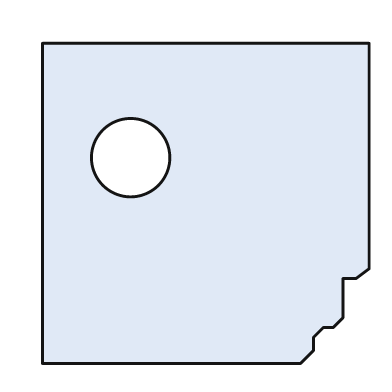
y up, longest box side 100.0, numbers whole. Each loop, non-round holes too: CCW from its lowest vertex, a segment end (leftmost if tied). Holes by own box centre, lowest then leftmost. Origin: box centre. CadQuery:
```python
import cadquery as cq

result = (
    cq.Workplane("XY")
    .moveTo(-50.0, -49.0)
    .lineTo(29.0, -49.0)
    .lineTo(33.0, -45.0)
    .lineTo(33.0, -41.0)
    .lineTo(36.0, -38.0)
    .lineTo(39.0, -38.0)
    .lineTo(42.0, -35.0)
    .lineTo(42.0, -23.0)
    .lineTo(46.0, -23.0)
    .lineTo(50.0, -20.0)
    .lineTo(50.0, 49.0)
    .lineTo(-50.0, 49.0)
    .close()
    .moveTo(-23.0, 14.0)
    .circle(12.0)
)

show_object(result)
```